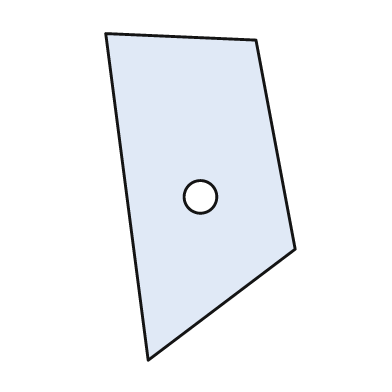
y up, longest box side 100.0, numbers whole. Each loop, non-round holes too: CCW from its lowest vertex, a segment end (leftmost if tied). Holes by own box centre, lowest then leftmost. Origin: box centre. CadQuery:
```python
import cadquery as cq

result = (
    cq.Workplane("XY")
    .moveTo(-16.0, -50.0)
    .lineTo(29.0, -16.0)
    .lineTo(17.0, 48.0)
    .lineTo(-29.0, 50.0)
    .close()
    .moveTo(0.0, 0.0)
    .circle(5.0)
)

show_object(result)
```